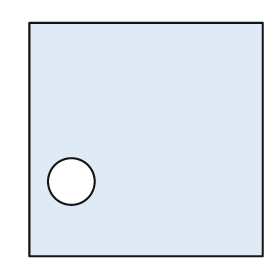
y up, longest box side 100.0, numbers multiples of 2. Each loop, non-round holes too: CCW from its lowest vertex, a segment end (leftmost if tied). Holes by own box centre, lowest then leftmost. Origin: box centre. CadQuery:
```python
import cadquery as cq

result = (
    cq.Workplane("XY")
    .moveTo(-50.0, -50.0)
    .lineTo(50.0, -50.0)
    .lineTo(50.0, 50.0)
    .lineTo(-50.0, 50.0)
    .close()
    .moveTo(-32.0, -18.0)
    .circle(10.0)
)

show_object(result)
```